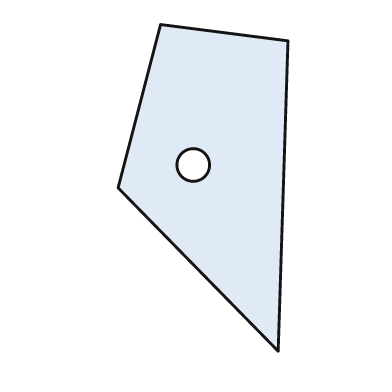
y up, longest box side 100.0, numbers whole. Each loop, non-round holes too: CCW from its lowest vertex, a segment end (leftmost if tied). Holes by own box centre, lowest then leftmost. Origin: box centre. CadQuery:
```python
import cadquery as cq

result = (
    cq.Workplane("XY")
    .moveTo(23.0, -50.0)
    .lineTo(26.0, 45.0)
    .lineTo(-13.0, 50.0)
    .lineTo(-26.0, 0.0)
    .close()
    .moveTo(-3.0, 7.0)
    .circle(5.0)
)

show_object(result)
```